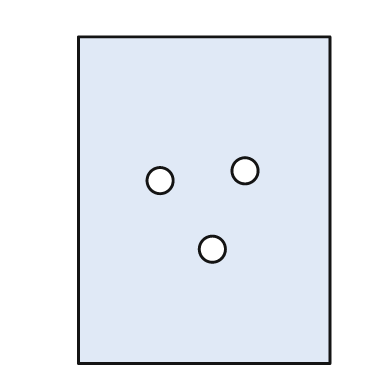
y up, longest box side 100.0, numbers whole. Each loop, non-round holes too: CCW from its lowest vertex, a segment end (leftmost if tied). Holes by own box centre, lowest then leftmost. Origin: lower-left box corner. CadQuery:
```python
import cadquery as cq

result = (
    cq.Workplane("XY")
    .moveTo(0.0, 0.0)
    .lineTo(77.0, 0.0)
    .lineTo(77.0, 100.0)
    .lineTo(0.0, 100.0)
    .close()
    .moveTo(41.0, 35.0)
    .circle(4.0)
    .moveTo(25.0, 56.0)
    .circle(4.0)
    .moveTo(51.0, 59.0)
    .circle(4.0)
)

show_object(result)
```